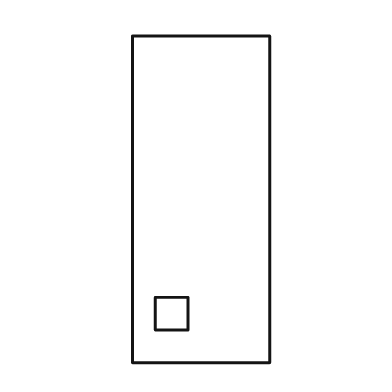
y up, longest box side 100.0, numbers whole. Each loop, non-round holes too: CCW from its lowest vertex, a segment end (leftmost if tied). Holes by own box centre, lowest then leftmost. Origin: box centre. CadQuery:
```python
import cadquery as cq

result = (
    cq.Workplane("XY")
    .moveTo(-21.0, -50.0)
    .lineTo(21.0, -50.0)
    .lineTo(21.0, 50.0)
    .lineTo(-21.0, 50.0)
    .close()
    .moveTo(-14.0, -40.0)
    .lineTo(-4.0, -40.0)
    .lineTo(-4.0, -30.0)
    .lineTo(-14.0, -30.0)
    .close()
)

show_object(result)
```